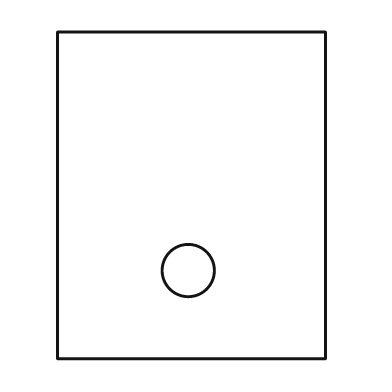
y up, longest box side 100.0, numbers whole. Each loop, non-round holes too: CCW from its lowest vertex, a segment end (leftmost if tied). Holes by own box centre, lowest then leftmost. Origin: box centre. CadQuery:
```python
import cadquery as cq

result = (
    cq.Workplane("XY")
    .moveTo(-41.0, -50.0)
    .lineTo(41.0, -50.0)
    .lineTo(41.0, 50.0)
    .lineTo(-41.0, 50.0)
    .close()
    .moveTo(-1.0, -23.0)
    .circle(8.0)
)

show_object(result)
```